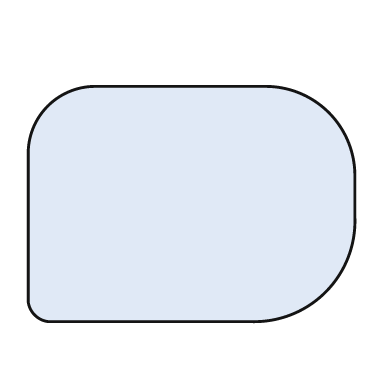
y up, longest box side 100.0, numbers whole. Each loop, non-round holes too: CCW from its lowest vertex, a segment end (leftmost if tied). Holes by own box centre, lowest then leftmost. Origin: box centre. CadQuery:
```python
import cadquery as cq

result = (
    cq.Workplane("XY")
    .moveTo(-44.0, -36.0)
    .lineTo(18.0, -36.0)
    .threePointArc((41.0, -27.0), (50.0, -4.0))
    .lineTo(50.0, 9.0)
    .threePointArc((42.0, 28.0), (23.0, 36.0))
    .lineTo(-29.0, 36.0)
    .threePointArc((-44.0, 30.0), (-50.0, 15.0))
    .lineTo(-50.0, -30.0)
    .threePointArc((-48.0, -34.0), (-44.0, -36.0))
    .close()
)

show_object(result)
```